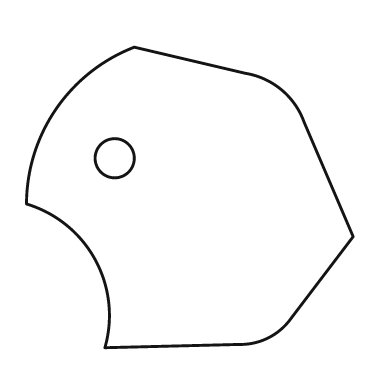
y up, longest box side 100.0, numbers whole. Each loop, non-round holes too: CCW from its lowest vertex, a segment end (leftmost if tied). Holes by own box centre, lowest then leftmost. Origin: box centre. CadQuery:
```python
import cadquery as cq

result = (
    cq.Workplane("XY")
    .moveTo(-26.0, -46.0)
    .lineTo(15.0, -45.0)
    .threePointArc((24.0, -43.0), (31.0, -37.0))
    .lineTo(50.0, -12.0)
    .lineTo(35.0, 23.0)
    .threePointArc((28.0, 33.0), (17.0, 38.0))
    .lineTo(-17.0, 46.0)
    .threePointArc((-41.0, 27.0), (-50.0, -2.0))
    .threePointArc((-29.0, -19.0), (-26.0, -46.0))
    .close()
    .moveTo(-23.0, 12.0)
    .circle(6.0)
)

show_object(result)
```